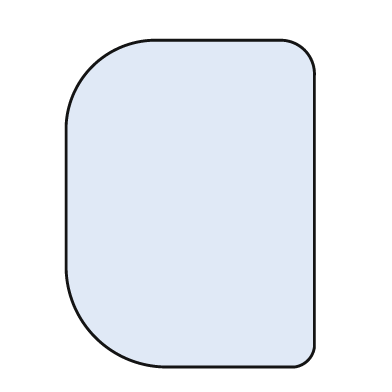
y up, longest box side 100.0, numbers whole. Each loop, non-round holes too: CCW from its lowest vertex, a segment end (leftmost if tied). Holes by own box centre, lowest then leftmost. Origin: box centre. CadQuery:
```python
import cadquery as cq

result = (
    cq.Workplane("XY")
    .moveTo(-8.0, -50.0)
    .lineTo(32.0, -50.0)
    .threePointArc((36.0, -48.0), (38.0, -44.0))
    .lineTo(38.0, 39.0)
    .threePointArc((35.0, 47.0), (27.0, 50.0))
    .lineTo(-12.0, 50.0)
    .threePointArc((-30.0, 42.0), (-38.0, 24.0))
    .lineTo(-38.0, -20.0)
    .threePointArc((-29.0, -41.0), (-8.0, -50.0))
    .close()
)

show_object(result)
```